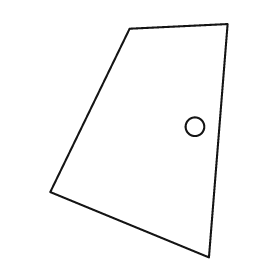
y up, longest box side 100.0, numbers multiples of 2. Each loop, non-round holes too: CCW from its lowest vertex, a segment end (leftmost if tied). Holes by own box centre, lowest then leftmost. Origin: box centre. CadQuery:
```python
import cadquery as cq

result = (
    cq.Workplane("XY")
    .moveTo(30.0, -50.0)
    .lineTo(38.0, 50.0)
    .lineTo(-4.0, 48.0)
    .lineTo(-38.0, -22.0)
    .close()
    .moveTo(24.0, 6.0)
    .circle(4.0)
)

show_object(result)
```